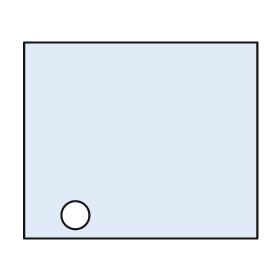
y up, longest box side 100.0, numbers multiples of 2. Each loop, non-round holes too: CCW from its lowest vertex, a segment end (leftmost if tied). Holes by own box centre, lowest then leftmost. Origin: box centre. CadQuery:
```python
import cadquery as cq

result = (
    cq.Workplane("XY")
    .moveTo(-50.0, -42.0)
    .lineTo(50.0, -42.0)
    .lineTo(50.0, 42.0)
    .lineTo(-50.0, 42.0)
    .close()
    .moveTo(-28.0, -32.0)
    .circle(6.0)
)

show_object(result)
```